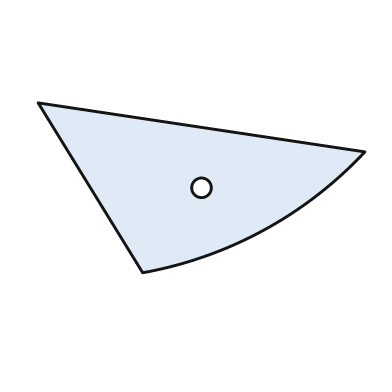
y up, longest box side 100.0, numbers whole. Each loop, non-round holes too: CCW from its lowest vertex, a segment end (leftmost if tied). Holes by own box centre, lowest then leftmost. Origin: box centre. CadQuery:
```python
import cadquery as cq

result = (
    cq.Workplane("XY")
    .moveTo(-18.0, -26.0)
    .threePointArc((19.0, -13.0), (50.0, 11.0))
    .lineTo(-50.0, 26.0)
    .close()
    .moveTo(0.0, 0.0)
    .circle(3.0)
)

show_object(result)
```